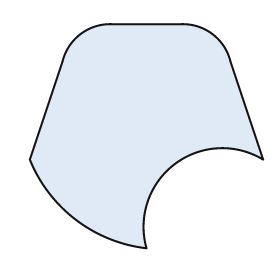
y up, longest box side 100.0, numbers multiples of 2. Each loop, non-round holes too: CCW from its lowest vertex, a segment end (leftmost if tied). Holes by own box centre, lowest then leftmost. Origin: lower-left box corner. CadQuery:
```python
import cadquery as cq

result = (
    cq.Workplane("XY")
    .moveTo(50.0, 0.0)
    .threePointArc((62.0, 36.0), (100.0, 38.0))
    .lineTo(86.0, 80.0)
    .threePointArc((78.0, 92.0), (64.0, 96.0))
    .lineTo(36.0, 96.0)
    .threePointArc((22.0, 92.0), (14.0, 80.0))
    .lineTo(0.0, 38.0)
    .threePointArc((20.0, 12.0), (50.0, 0.0))
    .close()
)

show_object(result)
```